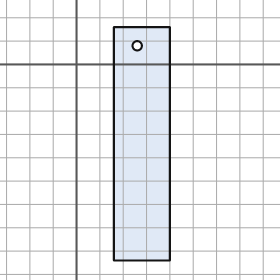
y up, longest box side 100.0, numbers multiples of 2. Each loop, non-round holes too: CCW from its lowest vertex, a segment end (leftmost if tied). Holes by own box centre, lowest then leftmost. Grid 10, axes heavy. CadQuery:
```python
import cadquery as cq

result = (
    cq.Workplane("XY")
    .moveTo(16.0, -84.0)
    .lineTo(40.0, -84.0)
    .lineTo(40.0, 16.0)
    .lineTo(16.0, 16.0)
    .close()
    .moveTo(26.0, 8.0)
    .circle(2.0)
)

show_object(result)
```